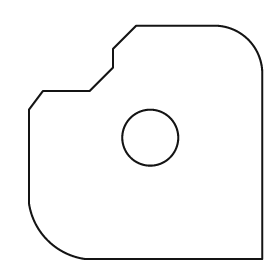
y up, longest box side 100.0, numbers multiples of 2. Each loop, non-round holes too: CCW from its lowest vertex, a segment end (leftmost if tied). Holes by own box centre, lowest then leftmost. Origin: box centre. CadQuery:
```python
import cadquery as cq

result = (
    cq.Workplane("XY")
    .moveTo(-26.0, -50.0)
    .lineTo(50.0, -50.0)
    .lineTo(50.0, 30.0)
    .threePointArc((44.0, 44.0), (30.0, 50.0))
    .lineTo(-4.0, 50.0)
    .lineTo(-14.0, 40.0)
    .lineTo(-14.0, 32.0)
    .lineTo(-24.0, 22.0)
    .lineTo(-44.0, 22.0)
    .lineTo(-50.0, 14.0)
    .lineTo(-50.0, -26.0)
    .threePointArc((-42.0, -42.0), (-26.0, -50.0))
    .close()
    .moveTo(2.0, 2.0)
    .circle(12.0)
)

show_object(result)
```